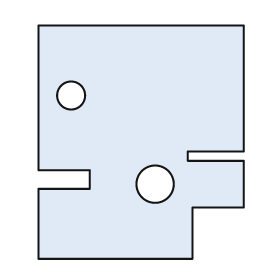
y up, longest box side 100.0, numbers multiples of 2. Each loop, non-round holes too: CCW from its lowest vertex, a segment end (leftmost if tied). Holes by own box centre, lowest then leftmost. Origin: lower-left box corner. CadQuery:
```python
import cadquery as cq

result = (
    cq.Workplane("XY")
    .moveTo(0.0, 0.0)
    .lineTo(66.0, 0.0)
    .lineTo(66.0, 22.0)
    .lineTo(88.0, 22.0)
    .lineTo(88.0, 42.0)
    .lineTo(64.0, 42.0)
    .lineTo(64.0, 46.0)
    .lineTo(88.0, 46.0)
    .lineTo(88.0, 100.0)
    .lineTo(0.0, 100.0)
    .lineTo(0.0, 38.0)
    .lineTo(22.0, 38.0)
    .lineTo(22.0, 30.0)
    .lineTo(0.0, 30.0)
    .close()
    .moveTo(50.0, 32.0)
    .circle(8.0)
    .moveTo(14.0, 70.0)
    .circle(6.0)
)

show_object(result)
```